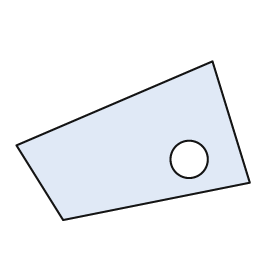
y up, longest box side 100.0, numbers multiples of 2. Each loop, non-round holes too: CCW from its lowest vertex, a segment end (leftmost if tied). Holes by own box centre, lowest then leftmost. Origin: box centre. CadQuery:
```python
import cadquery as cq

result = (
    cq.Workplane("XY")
    .moveTo(-30.0, -34.0)
    .lineTo(50.0, -18.0)
    .lineTo(34.0, 34.0)
    .lineTo(-50.0, -2.0)
    .close()
    .moveTo(24.0, -8.0)
    .circle(8.0)
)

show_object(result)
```